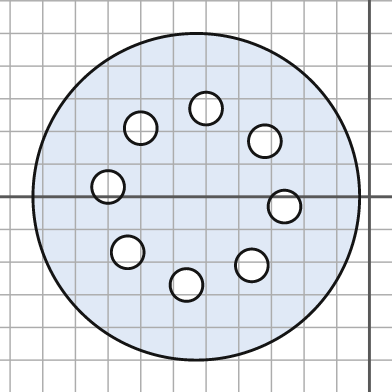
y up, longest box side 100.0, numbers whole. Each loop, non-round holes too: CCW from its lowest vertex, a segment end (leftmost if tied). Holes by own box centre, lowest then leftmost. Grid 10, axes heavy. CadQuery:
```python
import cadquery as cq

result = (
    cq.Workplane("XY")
    .moveTo(-53.0, 0.0)
    .circle(50.0)
    .moveTo(-56.0, -27.0)
    .circle(5.0)
    .moveTo(-36.0, -21.0)
    .circle(5.0)
    .moveTo(-74.0, -17.0)
    .circle(5.0)
    .moveTo(-26.0, -3.0)
    .circle(5.0)
    .moveTo(-80.0, 3.0)
    .circle(5.0)
    .moveTo(-32.0, 17.0)
    .circle(5.0)
    .moveTo(-70.0, 21.0)
    .circle(5.0)
    .moveTo(-50.0, 27.0)
    .circle(5.0)
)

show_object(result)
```